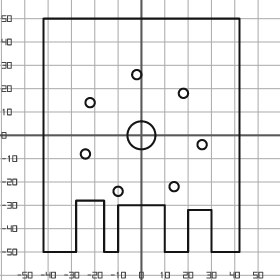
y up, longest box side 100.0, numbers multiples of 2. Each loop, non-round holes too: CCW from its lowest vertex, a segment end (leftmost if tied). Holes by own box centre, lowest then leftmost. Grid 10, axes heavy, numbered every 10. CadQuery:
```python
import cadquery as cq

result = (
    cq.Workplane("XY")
    .moveTo(-42.0, -50.0)
    .lineTo(-28.0, -50.0)
    .lineTo(-28.0, -28.0)
    .lineTo(-16.0, -28.0)
    .lineTo(-16.0, -50.0)
    .lineTo(-10.0, -50.0)
    .lineTo(-10.0, -30.0)
    .lineTo(10.0, -30.0)
    .lineTo(10.0, -50.0)
    .lineTo(20.0, -50.0)
    .lineTo(20.0, -32.0)
    .lineTo(30.0, -32.0)
    .lineTo(30.0, -50.0)
    .lineTo(42.0, -50.0)
    .lineTo(42.0, 50.0)
    .lineTo(-42.0, 50.0)
    .close()
    .moveTo(-10.0, -24.0)
    .circle(2.0)
    .moveTo(14.0, -22.0)
    .circle(2.0)
    .moveTo(-24.0, -8.0)
    .circle(2.0)
    .moveTo(26.0, -4.0)
    .circle(2.0)
    .moveTo(0.0, 0.0)
    .circle(6.0)
    .moveTo(-22.0, 14.0)
    .circle(2.0)
    .moveTo(18.0, 18.0)
    .circle(2.0)
    .moveTo(-2.0, 26.0)
    .circle(2.0)
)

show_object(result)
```